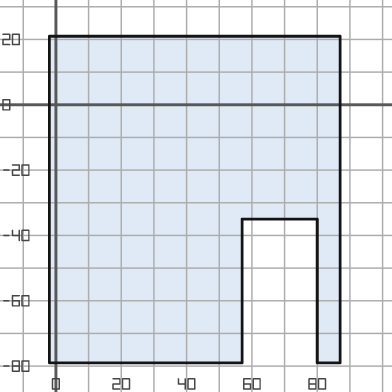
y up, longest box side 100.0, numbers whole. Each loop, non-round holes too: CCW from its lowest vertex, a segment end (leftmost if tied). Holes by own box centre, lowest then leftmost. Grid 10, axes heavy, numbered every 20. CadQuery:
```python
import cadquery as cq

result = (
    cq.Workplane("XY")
    .moveTo(-2.0, -79.0)
    .lineTo(57.0, -79.0)
    .lineTo(57.0, -35.0)
    .lineTo(80.0, -35.0)
    .lineTo(80.0, -79.0)
    .lineTo(87.0, -79.0)
    .lineTo(87.0, 21.0)
    .lineTo(-2.0, 21.0)
    .close()
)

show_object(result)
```